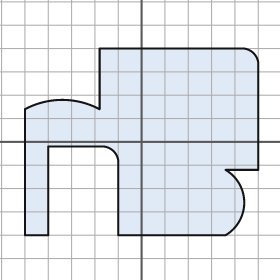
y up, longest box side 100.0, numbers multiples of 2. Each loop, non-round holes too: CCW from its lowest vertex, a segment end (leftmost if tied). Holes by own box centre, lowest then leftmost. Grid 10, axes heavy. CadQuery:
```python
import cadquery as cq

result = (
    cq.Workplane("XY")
    .moveTo(-50.0, -40.0)
    .lineTo(-40.0, -40.0)
    .lineTo(-40.0, -2.0)
    .lineTo(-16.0, -2.0)
    .threePointArc((-12.0, -4.0), (-10.0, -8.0))
    .lineTo(-10.0, -40.0)
    .lineTo(36.0, -40.0)
    .threePointArc((44.0, -26.0), (36.0, -12.0))
    .lineTo(50.0, -12.0)
    .lineTo(50.0, 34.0)
    .threePointArc((48.0, 38.0), (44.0, 40.0))
    .lineTo(-18.0, 40.0)
    .lineTo(-18.0, 14.0)
    .threePointArc((-34.0, 18.0), (-50.0, 14.0))
    .close()
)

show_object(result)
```